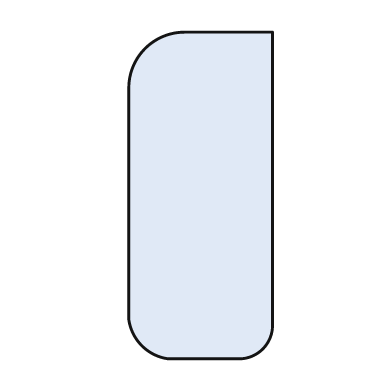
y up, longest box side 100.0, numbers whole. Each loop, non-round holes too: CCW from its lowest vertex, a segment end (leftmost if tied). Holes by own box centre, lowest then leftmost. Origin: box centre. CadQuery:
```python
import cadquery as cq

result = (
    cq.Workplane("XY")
    .moveTo(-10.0, -50.0)
    .lineTo(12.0, -50.0)
    .threePointArc((19.0, -47.0), (22.0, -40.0))
    .lineTo(22.0, 50.0)
    .lineTo(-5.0, 50.0)
    .threePointArc((-17.0, 45.0), (-22.0, 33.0))
    .lineTo(-22.0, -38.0)
    .threePointArc((-18.0, -46.0), (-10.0, -50.0))
    .close()
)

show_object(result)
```